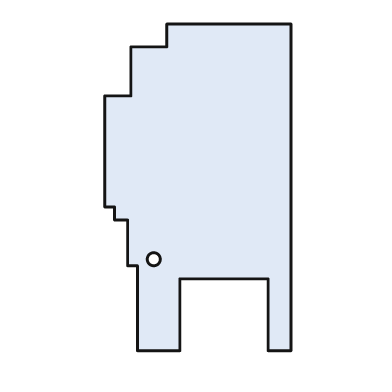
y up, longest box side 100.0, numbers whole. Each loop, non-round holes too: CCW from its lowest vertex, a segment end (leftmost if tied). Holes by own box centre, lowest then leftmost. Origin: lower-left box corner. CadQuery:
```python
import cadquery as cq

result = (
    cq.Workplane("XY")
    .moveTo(10.0, 0.0)
    .lineTo(23.0, 0.0)
    .lineTo(23.0, 22.0)
    .lineTo(50.0, 22.0)
    .lineTo(50.0, 0.0)
    .lineTo(57.0, 0.0)
    .lineTo(57.0, 100.0)
    .lineTo(19.0, 100.0)
    .lineTo(19.0, 93.0)
    .lineTo(8.0, 93.0)
    .lineTo(8.0, 78.0)
    .lineTo(0.0, 78.0)
    .lineTo(0.0, 44.0)
    .lineTo(3.0, 44.0)
    .lineTo(3.0, 40.0)
    .lineTo(7.0, 40.0)
    .lineTo(7.0, 26.0)
    .lineTo(10.0, 26.0)
    .close()
    .moveTo(15.0, 28.0)
    .circle(2.0)
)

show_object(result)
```